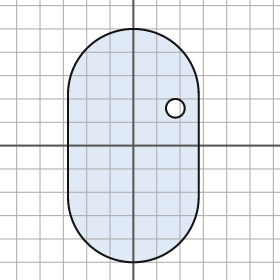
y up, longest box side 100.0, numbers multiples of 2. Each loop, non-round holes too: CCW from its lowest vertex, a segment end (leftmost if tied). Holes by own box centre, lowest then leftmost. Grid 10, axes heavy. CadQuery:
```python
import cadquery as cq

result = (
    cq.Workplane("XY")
    .moveTo(-28.0, -22.0)
    .threePointArc((0.0, -50.0), (28.0, -22.0))
    .lineTo(28.0, 22.0)
    .threePointArc((0.0, 50.0), (-28.0, 22.0))
    .close()
    .moveTo(18.0, 16.0)
    .circle(4.0)
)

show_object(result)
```